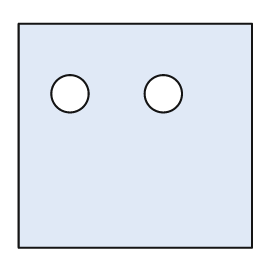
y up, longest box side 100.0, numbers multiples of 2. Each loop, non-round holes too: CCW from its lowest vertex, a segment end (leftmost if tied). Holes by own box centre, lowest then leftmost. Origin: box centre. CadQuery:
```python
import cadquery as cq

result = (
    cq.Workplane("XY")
    .moveTo(-50.0, -48.0)
    .lineTo(50.0, -48.0)
    .lineTo(50.0, 48.0)
    .lineTo(-50.0, 48.0)
    .close()
    .moveTo(-28.0, 18.0)
    .circle(8.0)
    .moveTo(12.0, 18.0)
    .circle(8.0)
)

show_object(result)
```